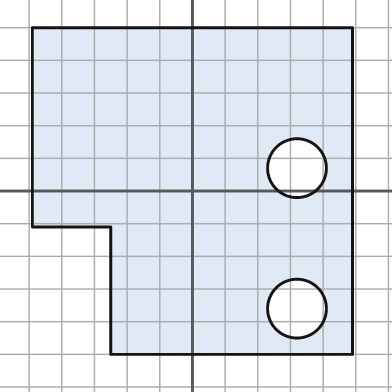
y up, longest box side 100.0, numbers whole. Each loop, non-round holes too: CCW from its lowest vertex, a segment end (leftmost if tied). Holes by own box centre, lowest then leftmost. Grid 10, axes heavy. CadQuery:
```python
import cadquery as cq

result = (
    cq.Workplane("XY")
    .moveTo(-25.0, -50.0)
    .lineTo(49.0, -50.0)
    .lineTo(49.0, 50.0)
    .lineTo(-49.0, 50.0)
    .lineTo(-49.0, -11.0)
    .lineTo(-25.0, -11.0)
    .close()
    .moveTo(32.0, -36.0)
    .circle(9.0)
    .moveTo(32.0, 7.0)
    .circle(9.0)
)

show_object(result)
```